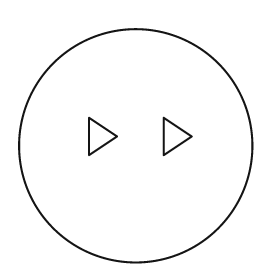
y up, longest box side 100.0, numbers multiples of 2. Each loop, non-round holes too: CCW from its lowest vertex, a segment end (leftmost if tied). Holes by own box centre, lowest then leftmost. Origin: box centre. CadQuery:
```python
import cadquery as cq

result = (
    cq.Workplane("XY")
    .moveTo(0.0, 0.0)
    .circle(50.0)
    .moveTo(-20.0, -4.0)
    .lineTo(-8.0, 4.0)
    .lineTo(-20.0, 12.0)
    .close()
    .moveTo(12.0, -4.0)
    .lineTo(24.0, 4.0)
    .lineTo(12.0, 12.0)
    .close()
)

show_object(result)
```